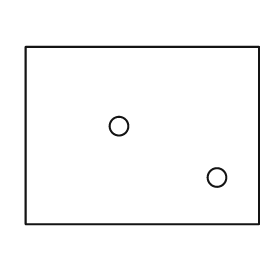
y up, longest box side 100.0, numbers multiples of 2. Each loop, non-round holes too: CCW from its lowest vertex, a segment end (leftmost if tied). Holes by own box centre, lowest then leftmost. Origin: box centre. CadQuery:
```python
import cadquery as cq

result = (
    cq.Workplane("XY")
    .moveTo(-50.0, -38.0)
    .lineTo(50.0, -38.0)
    .lineTo(50.0, 38.0)
    .lineTo(-50.0, 38.0)
    .close()
    .moveTo(32.0, -18.0)
    .circle(4.0)
    .moveTo(-10.0, 4.0)
    .circle(4.0)
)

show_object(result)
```